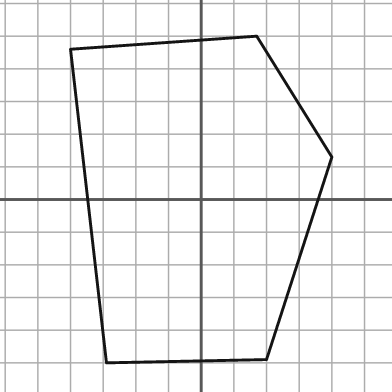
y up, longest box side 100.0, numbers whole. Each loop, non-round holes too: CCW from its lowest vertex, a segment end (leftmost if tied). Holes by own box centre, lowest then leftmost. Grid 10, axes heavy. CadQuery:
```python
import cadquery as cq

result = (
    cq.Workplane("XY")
    .moveTo(-29.0, -50.0)
    .lineTo(20.0, -49.0)
    .lineTo(40.0, 13.0)
    .lineTo(17.0, 50.0)
    .lineTo(-40.0, 46.0)
    .close()
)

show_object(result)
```